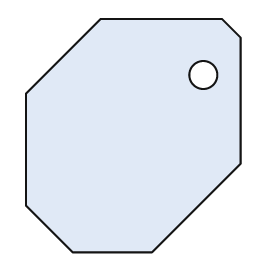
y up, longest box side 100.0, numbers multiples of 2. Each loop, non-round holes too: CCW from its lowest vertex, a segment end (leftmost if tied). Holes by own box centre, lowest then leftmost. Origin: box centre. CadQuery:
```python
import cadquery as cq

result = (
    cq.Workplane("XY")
    .moveTo(-26.0, -50.0)
    .lineTo(8.0, -50.0)
    .lineTo(46.0, -12.0)
    .lineTo(46.0, 42.0)
    .lineTo(38.0, 50.0)
    .lineTo(-14.0, 50.0)
    .lineTo(-46.0, 18.0)
    .lineTo(-46.0, -30.0)
    .close()
    .moveTo(30.0, 26.0)
    .circle(6.0)
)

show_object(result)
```